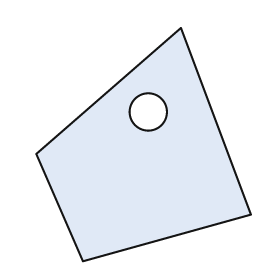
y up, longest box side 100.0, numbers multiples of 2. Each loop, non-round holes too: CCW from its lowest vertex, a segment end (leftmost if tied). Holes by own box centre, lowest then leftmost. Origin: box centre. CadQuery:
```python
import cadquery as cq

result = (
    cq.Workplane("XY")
    .moveTo(-26.0, -50.0)
    .lineTo(46.0, -30.0)
    .lineTo(16.0, 50.0)
    .lineTo(-46.0, -4.0)
    .close()
    .moveTo(2.0, 14.0)
    .circle(8.0)
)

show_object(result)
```